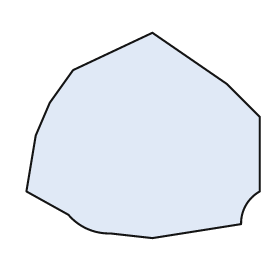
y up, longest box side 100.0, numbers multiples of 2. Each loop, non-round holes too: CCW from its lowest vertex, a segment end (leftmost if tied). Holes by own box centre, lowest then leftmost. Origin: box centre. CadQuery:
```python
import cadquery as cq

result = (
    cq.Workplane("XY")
    .moveTo(4.0, -44.0)
    .lineTo(42.0, -38.0)
    .threePointArc((44.0, -30.0), (50.0, -24.0))
    .lineTo(50.0, 8.0)
    .lineTo(36.0, 22.0)
    .lineTo(4.0, 44.0)
    .lineTo(-30.0, 28.0)
    .lineTo(-40.0, 14.0)
    .lineTo(-46.0, 0.0)
    .lineTo(-50.0, -24.0)
    .lineTo(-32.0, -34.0)
    .threePointArc((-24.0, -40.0), (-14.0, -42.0))
    .close()
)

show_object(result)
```